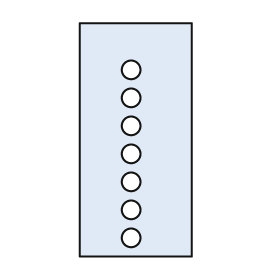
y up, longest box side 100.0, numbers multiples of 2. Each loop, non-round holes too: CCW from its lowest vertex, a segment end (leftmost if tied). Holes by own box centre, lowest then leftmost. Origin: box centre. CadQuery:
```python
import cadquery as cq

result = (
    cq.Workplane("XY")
    .moveTo(-24.0, -50.0)
    .lineTo(24.0, -50.0)
    .lineTo(24.0, 50.0)
    .lineTo(-24.0, 50.0)
    .close()
    .moveTo(-2.0, -42.0)
    .circle(4.0)
    .moveTo(-2.0, -30.0)
    .circle(4.0)
    .moveTo(-2.0, -18.0)
    .circle(4.0)
    .moveTo(-2.0, -6.0)
    .circle(4.0)
    .moveTo(-2.0, 6.0)
    .circle(4.0)
    .moveTo(-2.0, 18.0)
    .circle(4.0)
    .moveTo(-2.0, 30.0)
    .circle(4.0)
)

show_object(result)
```